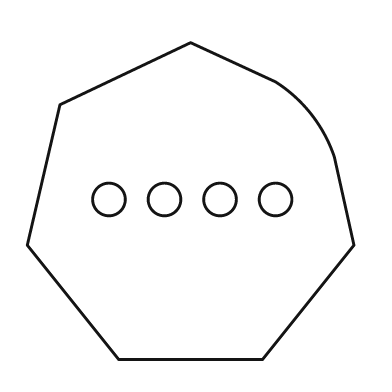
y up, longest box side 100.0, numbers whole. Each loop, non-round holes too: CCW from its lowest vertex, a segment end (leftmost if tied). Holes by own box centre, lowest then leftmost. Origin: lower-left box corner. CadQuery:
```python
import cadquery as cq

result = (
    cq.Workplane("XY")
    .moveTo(28.0, 0.0)
    .lineTo(72.0, 0.0)
    .lineTo(100.0, 35.0)
    .lineTo(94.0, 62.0)
    .threePointArc((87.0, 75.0), (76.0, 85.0))
    .lineTo(50.0, 97.0)
    .lineTo(10.0, 78.0)
    .lineTo(0.0, 35.0)
    .close()
    .moveTo(25.0, 49.0)
    .circle(5.0)
    .moveTo(42.0, 49.0)
    .circle(5.0)
    .moveTo(59.0, 49.0)
    .circle(5.0)
    .moveTo(76.0, 49.0)
    .circle(5.0)
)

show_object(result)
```